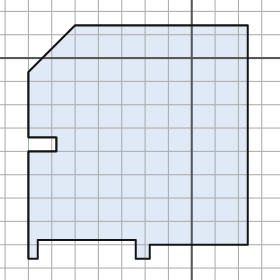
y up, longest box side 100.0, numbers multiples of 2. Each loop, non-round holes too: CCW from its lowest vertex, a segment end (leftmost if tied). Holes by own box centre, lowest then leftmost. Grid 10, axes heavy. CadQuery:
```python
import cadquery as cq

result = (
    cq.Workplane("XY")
    .moveTo(-70.0, -86.0)
    .lineTo(-66.0, -86.0)
    .lineTo(-66.0, -78.0)
    .lineTo(-24.0, -78.0)
    .lineTo(-24.0, -86.0)
    .lineTo(-18.0, -86.0)
    .lineTo(-18.0, -80.0)
    .lineTo(24.0, -80.0)
    .lineTo(24.0, 14.0)
    .lineTo(-50.0, 14.0)
    .lineTo(-70.0, -6.0)
    .lineTo(-70.0, -34.0)
    .lineTo(-58.0, -34.0)
    .lineTo(-58.0, -40.0)
    .lineTo(-70.0, -40.0)
    .close()
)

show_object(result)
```